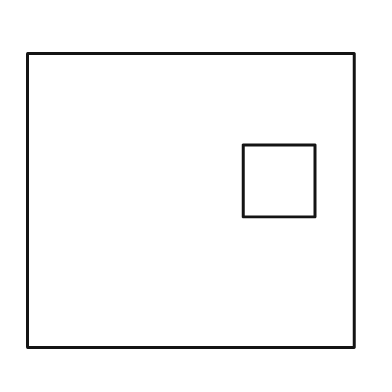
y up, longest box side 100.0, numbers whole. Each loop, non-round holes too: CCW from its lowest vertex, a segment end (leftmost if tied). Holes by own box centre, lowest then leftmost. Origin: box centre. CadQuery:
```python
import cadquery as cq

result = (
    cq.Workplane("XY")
    .moveTo(-50.0, -45.0)
    .lineTo(50.0, -45.0)
    .lineTo(50.0, 45.0)
    .lineTo(-50.0, 45.0)
    .close()
    .moveTo(16.0, -5.0)
    .lineTo(38.0, -5.0)
    .lineTo(38.0, 17.0)
    .lineTo(16.0, 17.0)
    .close()
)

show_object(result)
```